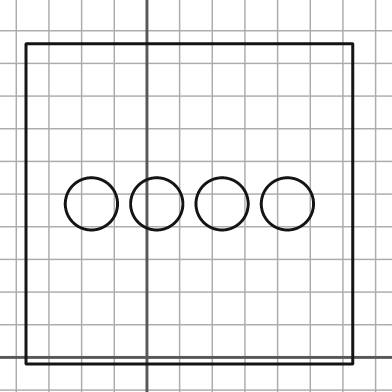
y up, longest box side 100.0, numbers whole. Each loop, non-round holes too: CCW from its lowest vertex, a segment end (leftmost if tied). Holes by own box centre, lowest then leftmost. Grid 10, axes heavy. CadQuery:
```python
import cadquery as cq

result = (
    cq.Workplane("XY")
    .moveTo(-37.0, -2.0)
    .lineTo(63.0, -2.0)
    .lineTo(63.0, 96.0)
    .lineTo(-37.0, 96.0)
    .close()
    .moveTo(-17.0, 47.0)
    .circle(8.0)
    .moveTo(3.0, 47.0)
    .circle(8.0)
    .moveTo(23.0, 47.0)
    .circle(8.0)
    .moveTo(43.0, 47.0)
    .circle(8.0)
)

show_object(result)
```